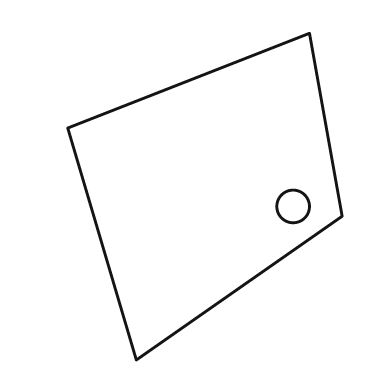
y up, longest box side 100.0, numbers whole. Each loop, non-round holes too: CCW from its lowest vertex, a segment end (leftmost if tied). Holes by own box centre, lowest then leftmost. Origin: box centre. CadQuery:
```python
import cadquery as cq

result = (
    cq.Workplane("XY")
    .moveTo(-21.0, -50.0)
    .lineTo(42.0, -6.0)
    .lineTo(32.0, 50.0)
    .lineTo(-42.0, 21.0)
    .close()
    .moveTo(27.0, -3.0)
    .circle(5.0)
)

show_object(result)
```